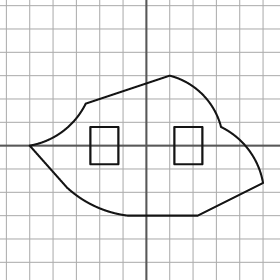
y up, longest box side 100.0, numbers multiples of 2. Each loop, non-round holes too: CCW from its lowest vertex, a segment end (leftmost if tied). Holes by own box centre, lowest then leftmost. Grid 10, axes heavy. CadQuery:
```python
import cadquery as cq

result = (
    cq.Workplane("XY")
    .moveTo(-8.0, -30.0)
    .lineTo(22.0, -30.0)
    .lineTo(50.0, -16.0)
    .threePointArc((44.0, -2.0), (32.0, 8.0))
    .threePointArc((24.0, 22.0), (10.0, 30.0))
    .lineTo(-26.0, 18.0)
    .threePointArc((-36.0, 6.0), (-50.0, 0.0))
    .lineTo(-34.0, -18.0)
    .threePointArc((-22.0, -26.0), (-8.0, -30.0))
    .close()
    .moveTo(-24.0, -8.0)
    .lineTo(-12.0, -8.0)
    .lineTo(-12.0, 8.0)
    .lineTo(-24.0, 8.0)
    .close()
    .moveTo(12.0, -8.0)
    .lineTo(24.0, -8.0)
    .lineTo(24.0, 8.0)
    .lineTo(12.0, 8.0)
    .close()
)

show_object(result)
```